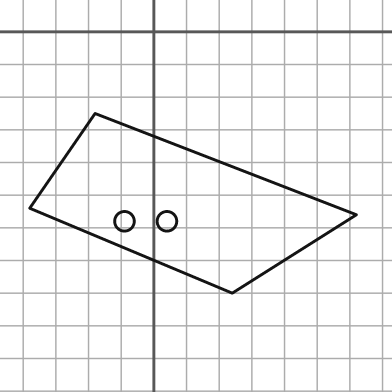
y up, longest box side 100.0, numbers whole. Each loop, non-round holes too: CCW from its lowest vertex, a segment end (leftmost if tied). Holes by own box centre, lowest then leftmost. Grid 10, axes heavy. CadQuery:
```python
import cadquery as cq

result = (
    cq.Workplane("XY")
    .moveTo(24.0, -80.0)
    .lineTo(62.0, -56.0)
    .lineTo(-18.0, -25.0)
    .lineTo(-38.0, -54.0)
    .close()
    .moveTo(-9.0, -58.0)
    .circle(3.0)
    .moveTo(4.0, -58.0)
    .circle(3.0)
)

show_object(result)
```